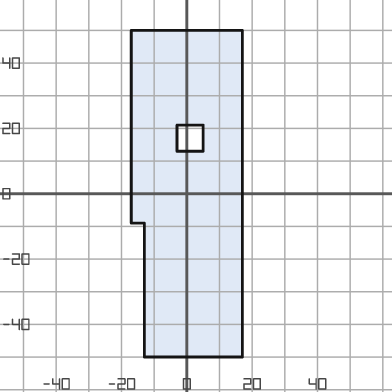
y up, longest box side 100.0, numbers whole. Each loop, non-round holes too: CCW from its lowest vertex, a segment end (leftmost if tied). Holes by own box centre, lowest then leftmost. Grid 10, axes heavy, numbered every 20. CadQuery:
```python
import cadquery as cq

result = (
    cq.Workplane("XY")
    .moveTo(-13.0, -50.0)
    .lineTo(17.0, -50.0)
    .lineTo(17.0, 50.0)
    .lineTo(-17.0, 50.0)
    .lineTo(-17.0, -9.0)
    .lineTo(-13.0, -9.0)
    .close()
    .moveTo(-3.0, 13.0)
    .lineTo(5.0, 13.0)
    .lineTo(5.0, 21.0)
    .lineTo(-3.0, 21.0)
    .close()
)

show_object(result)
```